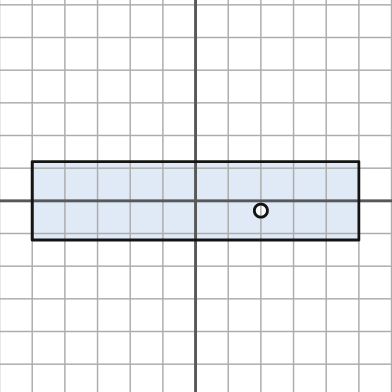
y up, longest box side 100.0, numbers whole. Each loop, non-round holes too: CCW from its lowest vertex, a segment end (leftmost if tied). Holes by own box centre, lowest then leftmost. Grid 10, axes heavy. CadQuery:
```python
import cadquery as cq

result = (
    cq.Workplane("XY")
    .moveTo(-50.0, -12.0)
    .lineTo(50.0, -12.0)
    .lineTo(50.0, 12.0)
    .lineTo(-50.0, 12.0)
    .close()
    .moveTo(20.0, -3.0)
    .circle(2.0)
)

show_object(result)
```